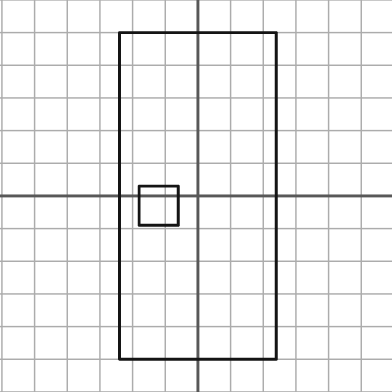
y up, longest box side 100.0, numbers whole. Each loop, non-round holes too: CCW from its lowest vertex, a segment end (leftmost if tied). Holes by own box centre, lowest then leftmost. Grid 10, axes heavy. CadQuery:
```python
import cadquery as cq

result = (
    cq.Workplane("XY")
    .moveTo(-24.0, -50.0)
    .lineTo(24.0, -50.0)
    .lineTo(24.0, 50.0)
    .lineTo(-24.0, 50.0)
    .close()
    .moveTo(-18.0, -9.0)
    .lineTo(-6.0, -9.0)
    .lineTo(-6.0, 3.0)
    .lineTo(-18.0, 3.0)
    .close()
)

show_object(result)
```